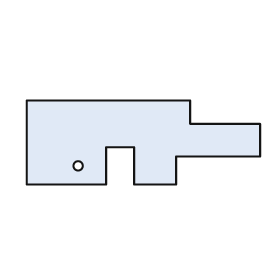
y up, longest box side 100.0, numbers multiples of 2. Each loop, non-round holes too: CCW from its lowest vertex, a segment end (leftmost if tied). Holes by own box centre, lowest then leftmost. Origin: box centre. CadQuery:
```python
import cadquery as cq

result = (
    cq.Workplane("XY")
    .moveTo(-50.0, -18.0)
    .lineTo(-16.0, -18.0)
    .lineTo(-16.0, -2.0)
    .lineTo(-4.0, -2.0)
    .lineTo(-4.0, -18.0)
    .lineTo(14.0, -18.0)
    .lineTo(14.0, -6.0)
    .lineTo(50.0, -6.0)
    .lineTo(50.0, 8.0)
    .lineTo(20.0, 8.0)
    .lineTo(20.0, 18.0)
    .lineTo(-50.0, 18.0)
    .close()
    .moveTo(-28.0, -10.0)
    .circle(2.0)
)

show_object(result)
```